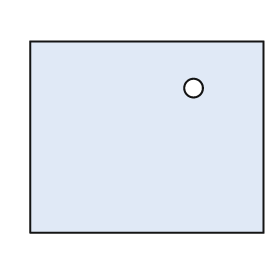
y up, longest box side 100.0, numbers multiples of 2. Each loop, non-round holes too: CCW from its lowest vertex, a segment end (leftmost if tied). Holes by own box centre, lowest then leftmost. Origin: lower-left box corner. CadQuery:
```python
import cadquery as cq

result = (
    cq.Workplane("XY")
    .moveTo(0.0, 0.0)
    .lineTo(100.0, 0.0)
    .lineTo(100.0, 82.0)
    .lineTo(0.0, 82.0)
    .close()
    .moveTo(70.0, 62.0)
    .circle(4.0)
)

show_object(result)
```